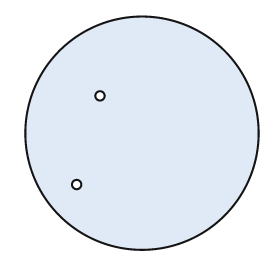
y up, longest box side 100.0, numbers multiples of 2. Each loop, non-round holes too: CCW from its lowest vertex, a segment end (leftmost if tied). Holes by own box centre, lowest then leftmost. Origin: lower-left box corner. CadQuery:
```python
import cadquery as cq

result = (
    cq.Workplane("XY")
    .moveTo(50.0, 50.0)
    .circle(50.0)
    .moveTo(22.0, 28.0)
    .circle(2.0)
    .moveTo(32.0, 66.0)
    .circle(2.0)
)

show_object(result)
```